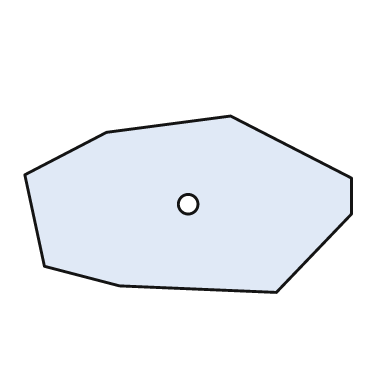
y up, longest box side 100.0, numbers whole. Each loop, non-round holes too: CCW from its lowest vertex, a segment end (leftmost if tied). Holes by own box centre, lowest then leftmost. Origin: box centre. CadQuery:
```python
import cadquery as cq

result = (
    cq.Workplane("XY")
    .moveTo(27.0, -27.0)
    .lineTo(50.0, -3.0)
    .lineTo(50.0, 8.0)
    .lineTo(13.0, 27.0)
    .lineTo(-25.0, 22.0)
    .lineTo(-50.0, 9.0)
    .lineTo(-44.0, -19.0)
    .lineTo(-21.0, -25.0)
    .close()
    .moveTo(0.0, 0.0)
    .circle(3.0)
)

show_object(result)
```